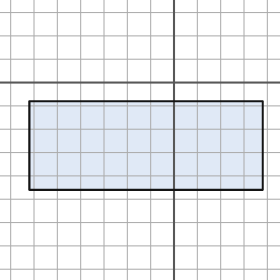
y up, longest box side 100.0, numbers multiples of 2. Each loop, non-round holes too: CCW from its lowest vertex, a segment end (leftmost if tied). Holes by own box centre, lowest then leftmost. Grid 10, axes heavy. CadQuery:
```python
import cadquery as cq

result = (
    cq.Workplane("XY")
    .moveTo(-62.0, -46.0)
    .lineTo(38.0, -46.0)
    .lineTo(38.0, -8.0)
    .lineTo(-62.0, -8.0)
    .close()
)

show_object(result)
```